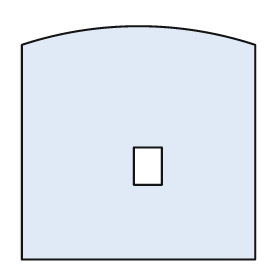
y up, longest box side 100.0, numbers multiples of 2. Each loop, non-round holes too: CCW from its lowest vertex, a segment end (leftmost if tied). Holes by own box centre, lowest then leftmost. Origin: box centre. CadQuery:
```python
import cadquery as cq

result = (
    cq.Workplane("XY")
    .moveTo(-50.0, -50.0)
    .lineTo(50.0, -50.0)
    .lineTo(50.0, 42.0)
    .threePointArc((0.0, 50.0), (-50.0, 42.0))
    .close()
    .moveTo(-2.0, -18.0)
    .lineTo(10.0, -18.0)
    .lineTo(10.0, -2.0)
    .lineTo(-2.0, -2.0)
    .close()
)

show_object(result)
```